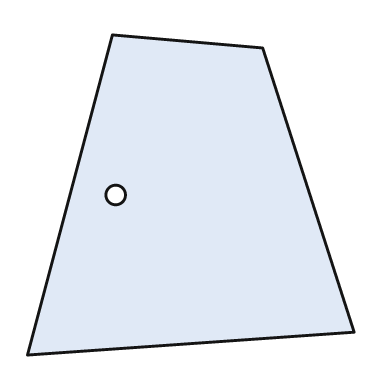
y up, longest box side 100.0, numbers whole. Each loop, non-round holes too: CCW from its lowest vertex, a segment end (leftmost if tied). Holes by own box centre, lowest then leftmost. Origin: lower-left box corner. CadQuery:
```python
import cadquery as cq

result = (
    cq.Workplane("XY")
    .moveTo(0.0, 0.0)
    .lineTo(100.0, 7.0)
    .lineTo(72.0, 94.0)
    .lineTo(26.0, 98.0)
    .close()
    .moveTo(27.0, 49.0)
    .circle(3.0)
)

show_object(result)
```